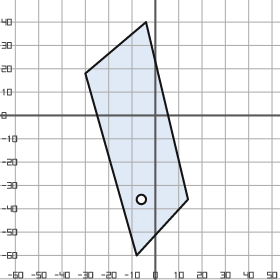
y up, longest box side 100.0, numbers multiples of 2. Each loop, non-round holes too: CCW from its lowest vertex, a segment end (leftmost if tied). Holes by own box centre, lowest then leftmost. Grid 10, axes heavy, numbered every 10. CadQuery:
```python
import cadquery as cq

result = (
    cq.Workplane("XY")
    .moveTo(-8.0, -60.0)
    .lineTo(14.0, -36.0)
    .lineTo(-4.0, 40.0)
    .lineTo(-30.0, 18.0)
    .close()
    .moveTo(-6.0, -36.0)
    .circle(2.0)
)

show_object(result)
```